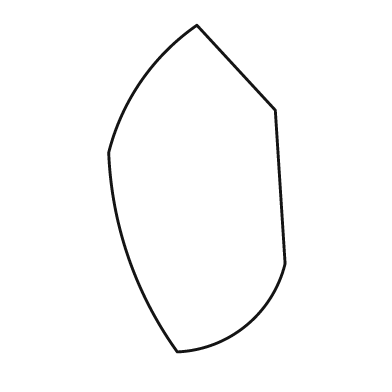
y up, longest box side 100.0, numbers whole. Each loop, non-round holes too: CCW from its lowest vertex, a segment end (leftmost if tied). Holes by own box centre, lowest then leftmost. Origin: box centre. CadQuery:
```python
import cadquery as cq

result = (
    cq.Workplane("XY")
    .moveTo(-6.0, -50.0)
    .threePointArc((15.0, -42.0), (27.0, -23.0))
    .lineTo(24.0, 24.0)
    .lineTo(0.0, 50.0)
    .threePointArc((-17.0, 33.0), (-27.0, 11.0))
    .threePointArc((-21.0, -21.0), (-6.0, -50.0))
    .close()
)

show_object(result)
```